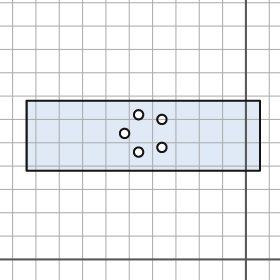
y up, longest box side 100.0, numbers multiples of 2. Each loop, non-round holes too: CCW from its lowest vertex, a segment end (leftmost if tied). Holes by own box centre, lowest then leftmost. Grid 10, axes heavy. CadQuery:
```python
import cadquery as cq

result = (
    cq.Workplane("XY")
    .moveTo(-94.0, 38.0)
    .lineTo(6.0, 38.0)
    .lineTo(6.0, 68.0)
    .lineTo(-94.0, 68.0)
    .close()
    .moveTo(-46.0, 46.0)
    .circle(2.0)
    .moveTo(-36.0, 48.0)
    .circle(2.0)
    .moveTo(-52.0, 54.0)
    .circle(2.0)
    .moveTo(-36.0, 60.0)
    .circle(2.0)
    .moveTo(-46.0, 62.0)
    .circle(2.0)
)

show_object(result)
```